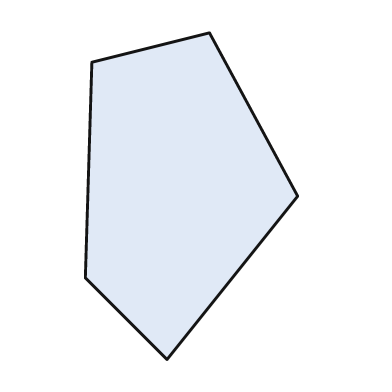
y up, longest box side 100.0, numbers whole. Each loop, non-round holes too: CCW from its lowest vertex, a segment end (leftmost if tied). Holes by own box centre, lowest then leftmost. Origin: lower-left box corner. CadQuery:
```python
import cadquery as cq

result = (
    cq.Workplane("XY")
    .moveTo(25.0, 0.0)
    .lineTo(65.0, 50.0)
    .lineTo(38.0, 100.0)
    .lineTo(2.0, 91.0)
    .lineTo(0.0, 25.0)
    .close()
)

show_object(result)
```